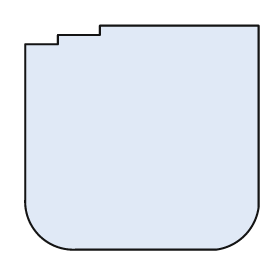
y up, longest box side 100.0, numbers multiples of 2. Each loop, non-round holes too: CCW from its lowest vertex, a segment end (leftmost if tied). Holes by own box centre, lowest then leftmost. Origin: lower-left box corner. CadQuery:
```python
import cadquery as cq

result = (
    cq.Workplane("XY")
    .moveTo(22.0, 0.0)
    .lineTo(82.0, 0.0)
    .threePointArc((94.0, 6.0), (100.0, 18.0))
    .lineTo(100.0, 96.0)
    .lineTo(32.0, 96.0)
    .lineTo(32.0, 92.0)
    .lineTo(14.0, 92.0)
    .lineTo(14.0, 88.0)
    .lineTo(0.0, 88.0)
    .lineTo(0.0, 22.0)
    .threePointArc((6.0, 6.0), (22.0, 0.0))
    .close()
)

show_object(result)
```